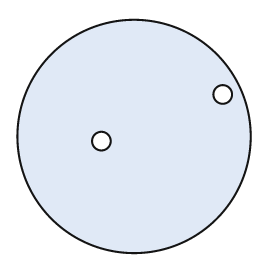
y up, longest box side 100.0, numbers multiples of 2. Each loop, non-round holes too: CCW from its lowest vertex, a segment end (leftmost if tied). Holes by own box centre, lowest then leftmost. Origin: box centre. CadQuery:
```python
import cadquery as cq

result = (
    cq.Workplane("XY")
    .moveTo(0.0, 0.0)
    .circle(50.0)
    .moveTo(-14.0, -2.0)
    .circle(4.0)
    .moveTo(38.0, 18.0)
    .circle(4.0)
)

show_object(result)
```